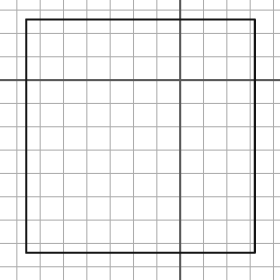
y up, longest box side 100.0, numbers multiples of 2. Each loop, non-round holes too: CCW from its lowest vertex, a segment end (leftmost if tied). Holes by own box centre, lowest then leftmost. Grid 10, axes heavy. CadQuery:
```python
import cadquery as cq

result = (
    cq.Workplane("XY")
    .moveTo(-66.0, -74.0)
    .lineTo(32.0, -74.0)
    .lineTo(32.0, 26.0)
    .lineTo(-66.0, 26.0)
    .close()
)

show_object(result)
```